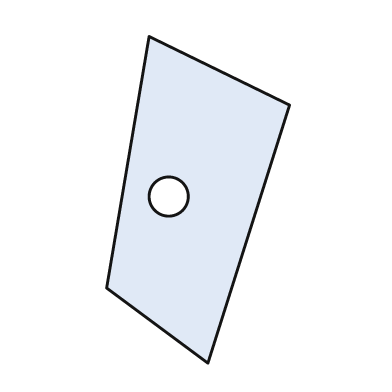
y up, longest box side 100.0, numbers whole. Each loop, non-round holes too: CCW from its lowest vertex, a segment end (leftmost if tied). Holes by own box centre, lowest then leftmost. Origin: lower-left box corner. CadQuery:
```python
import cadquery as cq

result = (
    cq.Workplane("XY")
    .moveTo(31.0, 0.0)
    .lineTo(56.0, 79.0)
    .lineTo(13.0, 100.0)
    .lineTo(0.0, 23.0)
    .close()
    .moveTo(19.0, 51.0)
    .circle(6.0)
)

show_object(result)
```